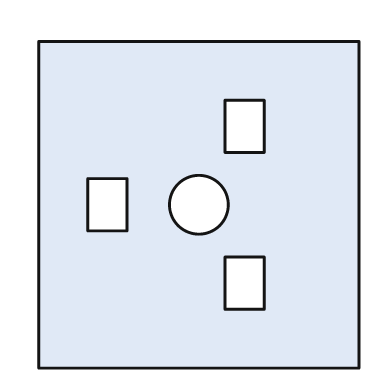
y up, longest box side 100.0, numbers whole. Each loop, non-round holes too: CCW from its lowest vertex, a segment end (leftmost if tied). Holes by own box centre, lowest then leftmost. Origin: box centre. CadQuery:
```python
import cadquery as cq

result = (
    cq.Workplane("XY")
    .moveTo(-49.0, -50.0)
    .lineTo(49.0, -50.0)
    .lineTo(49.0, 50.0)
    .lineTo(-49.0, 50.0)
    .close()
    .moveTo(8.0, -32.0)
    .lineTo(20.0, -32.0)
    .lineTo(20.0, -16.0)
    .lineTo(8.0, -16.0)
    .close()
    .moveTo(-34.0, -8.0)
    .lineTo(-22.0, -8.0)
    .lineTo(-22.0, 8.0)
    .lineTo(-34.0, 8.0)
    .close()
    .moveTo(0.0, 0.0)
    .circle(9.0)
    .moveTo(8.0, 16.0)
    .lineTo(20.0, 16.0)
    .lineTo(20.0, 32.0)
    .lineTo(8.0, 32.0)
    .close()
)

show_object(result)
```